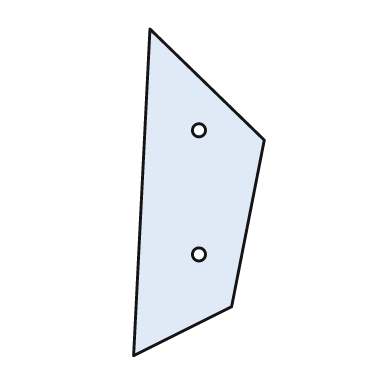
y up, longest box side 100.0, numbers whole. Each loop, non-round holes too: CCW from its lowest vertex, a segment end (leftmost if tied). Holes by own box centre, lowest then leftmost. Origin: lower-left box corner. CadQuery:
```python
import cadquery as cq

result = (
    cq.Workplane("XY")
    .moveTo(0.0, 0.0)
    .lineTo(30.0, 15.0)
    .lineTo(40.0, 66.0)
    .lineTo(5.0, 100.0)
    .close()
    .moveTo(20.0, 31.0)
    .circle(2.0)
    .moveTo(20.0, 69.0)
    .circle(2.0)
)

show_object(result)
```